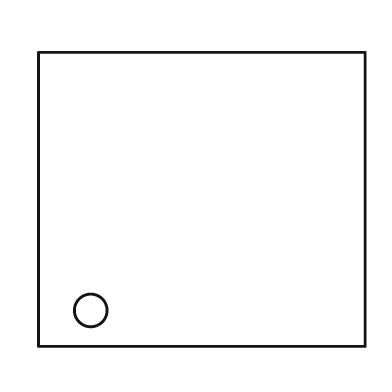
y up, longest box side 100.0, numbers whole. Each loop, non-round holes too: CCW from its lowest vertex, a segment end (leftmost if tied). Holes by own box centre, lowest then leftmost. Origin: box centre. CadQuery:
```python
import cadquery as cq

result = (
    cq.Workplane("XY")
    .moveTo(-50.0, -45.0)
    .lineTo(50.0, -45.0)
    .lineTo(50.0, 45.0)
    .lineTo(-50.0, 45.0)
    .close()
    .moveTo(-34.0, -34.0)
    .circle(5.0)
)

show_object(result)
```